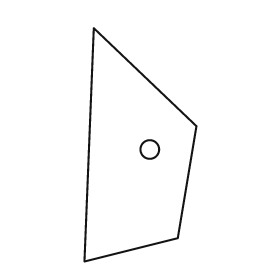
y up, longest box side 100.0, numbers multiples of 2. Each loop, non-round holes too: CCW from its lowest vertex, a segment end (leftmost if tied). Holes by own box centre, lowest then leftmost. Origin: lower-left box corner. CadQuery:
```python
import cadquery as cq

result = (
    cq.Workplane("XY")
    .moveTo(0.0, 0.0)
    .lineTo(40.0, 10.0)
    .lineTo(48.0, 58.0)
    .lineTo(4.0, 100.0)
    .close()
    .moveTo(28.0, 48.0)
    .circle(4.0)
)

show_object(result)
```